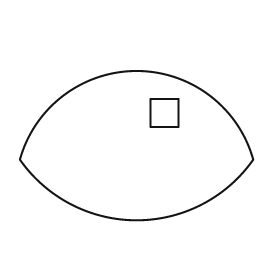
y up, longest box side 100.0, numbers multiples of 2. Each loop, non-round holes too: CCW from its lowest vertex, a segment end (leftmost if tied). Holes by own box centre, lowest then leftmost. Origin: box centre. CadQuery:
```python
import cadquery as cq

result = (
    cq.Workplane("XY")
    .moveTo(-50.0, -6.0)
    .threePointArc((0.0, -32.0), (50.0, -6.0))
    .threePointArc((0.0, 32.0), (-50.0, -6.0))
    .close()
    .moveTo(6.0, 8.0)
    .lineTo(18.0, 8.0)
    .lineTo(18.0, 20.0)
    .lineTo(6.0, 20.0)
    .close()
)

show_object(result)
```